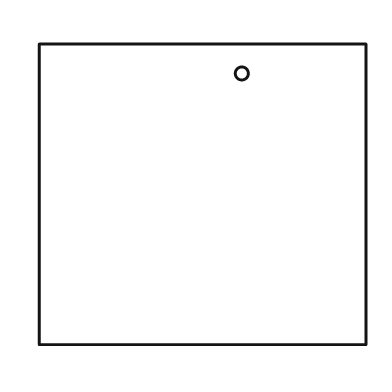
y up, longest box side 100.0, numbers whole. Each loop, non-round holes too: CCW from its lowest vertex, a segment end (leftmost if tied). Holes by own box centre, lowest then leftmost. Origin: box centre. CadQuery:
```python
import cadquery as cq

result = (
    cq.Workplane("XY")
    .moveTo(-50.0, -46.0)
    .lineTo(50.0, -46.0)
    .lineTo(50.0, 46.0)
    .lineTo(-50.0, 46.0)
    .close()
    .moveTo(12.0, 37.0)
    .circle(2.0)
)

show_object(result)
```